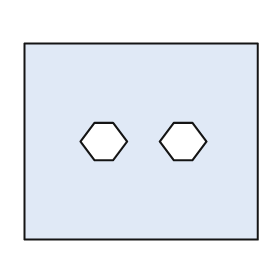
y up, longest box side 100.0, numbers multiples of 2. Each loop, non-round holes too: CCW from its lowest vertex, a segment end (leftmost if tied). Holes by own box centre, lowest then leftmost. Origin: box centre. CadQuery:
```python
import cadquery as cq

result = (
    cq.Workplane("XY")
    .moveTo(-50.0, -42.0)
    .lineTo(50.0, -42.0)
    .lineTo(50.0, 42.0)
    .lineTo(-50.0, 42.0)
    .close()
    .moveTo(-20.0, -8.0)
    .lineTo(-12.0, -8.0)
    .lineTo(-6.0, 0.0)
    .lineTo(-12.0, 8.0)
    .lineTo(-20.0, 8.0)
    .lineTo(-26.0, 0.0)
    .close()
    .moveTo(14.0, -8.0)
    .lineTo(22.0, -8.0)
    .lineTo(28.0, 0.0)
    .lineTo(22.0, 8.0)
    .lineTo(14.0, 8.0)
    .lineTo(8.0, 0.0)
    .close()
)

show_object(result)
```